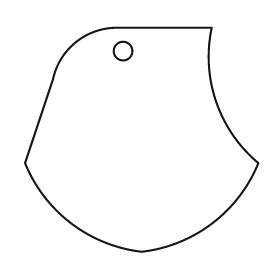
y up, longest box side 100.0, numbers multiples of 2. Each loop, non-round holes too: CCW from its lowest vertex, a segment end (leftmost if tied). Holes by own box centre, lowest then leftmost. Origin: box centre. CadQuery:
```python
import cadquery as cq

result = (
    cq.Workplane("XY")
    .moveTo(0.0, -48.0)
    .threePointArc((30.0, -36.0), (50.0, -10.0))
    .threePointArc((32.0, 16.0), (30.0, 48.0))
    .lineTo(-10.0, 48.0)
    .threePointArc((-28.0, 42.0), (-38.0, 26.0))
    .lineTo(-50.0, -10.0)
    .threePointArc((-30.0, -36.0), (0.0, -48.0))
    .close()
    .moveTo(-8.0, 38.0)
    .circle(4.0)
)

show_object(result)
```